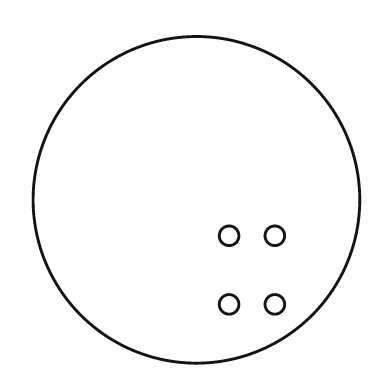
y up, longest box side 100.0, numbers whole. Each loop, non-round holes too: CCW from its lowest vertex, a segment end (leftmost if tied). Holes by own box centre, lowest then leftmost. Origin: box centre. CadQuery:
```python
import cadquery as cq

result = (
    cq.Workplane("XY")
    .moveTo(0.0, 0.0)
    .circle(50.0)
    .moveTo(10.0, -32.0)
    .circle(3.0)
    .moveTo(24.0, -32.0)
    .circle(3.0)
    .moveTo(10.0, -11.0)
    .circle(3.0)
    .moveTo(24.0, -11.0)
    .circle(3.0)
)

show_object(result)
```